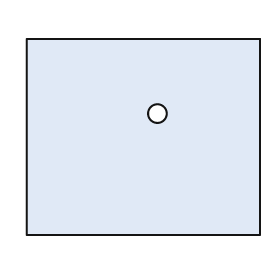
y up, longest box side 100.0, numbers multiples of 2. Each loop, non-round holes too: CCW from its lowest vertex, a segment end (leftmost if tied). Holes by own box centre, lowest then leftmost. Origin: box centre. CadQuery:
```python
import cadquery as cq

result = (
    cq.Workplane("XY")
    .moveTo(-50.0, -42.0)
    .lineTo(50.0, -42.0)
    .lineTo(50.0, 42.0)
    .lineTo(-50.0, 42.0)
    .close()
    .moveTo(6.0, 10.0)
    .circle(4.0)
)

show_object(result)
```